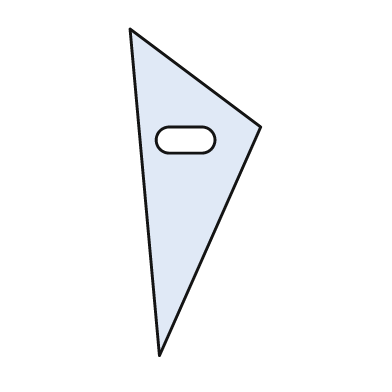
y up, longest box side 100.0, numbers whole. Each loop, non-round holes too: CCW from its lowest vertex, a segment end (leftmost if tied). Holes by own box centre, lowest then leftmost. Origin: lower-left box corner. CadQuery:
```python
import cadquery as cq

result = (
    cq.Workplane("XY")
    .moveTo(9.0, 0.0)
    .lineTo(40.0, 70.0)
    .lineTo(0.0, 100.0)
    .close()
    .moveTo(12.0, 62.0)
    .lineTo(22.0, 62.0)
    .threePointArc((26.0, 66.0), (22.0, 70.0))
    .lineTo(12.0, 70.0)
    .threePointArc((8.0, 66.0), (12.0, 62.0))
    .close()
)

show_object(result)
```